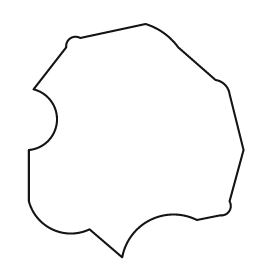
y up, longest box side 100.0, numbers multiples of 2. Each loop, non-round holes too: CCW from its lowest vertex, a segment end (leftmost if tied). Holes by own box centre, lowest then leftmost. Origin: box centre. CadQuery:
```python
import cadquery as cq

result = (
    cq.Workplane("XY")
    .moveTo(-6.0, -50.0)
    .threePointArc((6.0, -34.0), (26.0, -34.0))
    .lineTo(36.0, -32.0)
    .threePointArc((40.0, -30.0), (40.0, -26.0))
    .lineTo(46.0, -4.0)
    .lineTo(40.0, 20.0)
    .threePointArc((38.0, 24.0), (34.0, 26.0))
    .lineTo(18.0, 40.0)
    .threePointArc((12.0, 46.0), (4.0, 50.0))
    .lineTo(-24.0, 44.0)
    .threePointArc((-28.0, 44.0), (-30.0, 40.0))
    .lineTo(-44.0, 22.0)
    .threePointArc((-34.0, 8.0), (-46.0, -4.0))
    .lineTo(-46.0, -26.0)
    .threePointArc((-36.0, -38.0), (-20.0, -38.0))
    .close()
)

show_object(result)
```